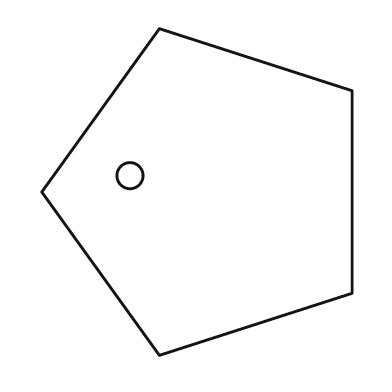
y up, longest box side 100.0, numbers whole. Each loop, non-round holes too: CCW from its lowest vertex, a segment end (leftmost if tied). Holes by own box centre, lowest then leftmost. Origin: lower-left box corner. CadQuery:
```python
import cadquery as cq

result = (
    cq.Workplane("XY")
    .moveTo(36.0, 0.0)
    .lineTo(95.0, 19.0)
    .lineTo(95.0, 81.0)
    .lineTo(36.0, 100.0)
    .lineTo(0.0, 50.0)
    .close()
    .moveTo(27.0, 55.0)
    .circle(4.0)
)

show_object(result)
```